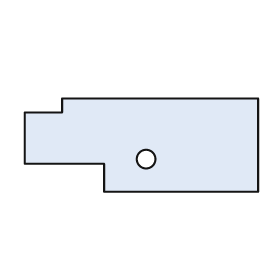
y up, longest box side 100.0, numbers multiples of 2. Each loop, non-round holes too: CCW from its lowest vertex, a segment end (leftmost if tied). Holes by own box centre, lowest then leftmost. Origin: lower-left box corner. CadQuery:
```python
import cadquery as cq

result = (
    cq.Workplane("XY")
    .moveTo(34.0, 0.0)
    .lineTo(100.0, 0.0)
    .lineTo(100.0, 40.0)
    .lineTo(16.0, 40.0)
    .lineTo(16.0, 34.0)
    .lineTo(0.0, 34.0)
    .lineTo(0.0, 12.0)
    .lineTo(34.0, 12.0)
    .close()
    .moveTo(52.0, 14.0)
    .circle(4.0)
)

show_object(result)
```